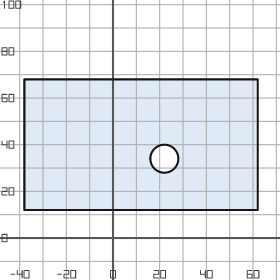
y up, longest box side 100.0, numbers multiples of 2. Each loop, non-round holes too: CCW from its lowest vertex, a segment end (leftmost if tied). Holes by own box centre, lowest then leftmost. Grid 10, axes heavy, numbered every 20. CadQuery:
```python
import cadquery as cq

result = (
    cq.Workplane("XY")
    .moveTo(-38.0, 12.0)
    .lineTo(62.0, 12.0)
    .lineTo(62.0, 68.0)
    .lineTo(-38.0, 68.0)
    .close()
    .moveTo(22.0, 34.0)
    .circle(6.0)
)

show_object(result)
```